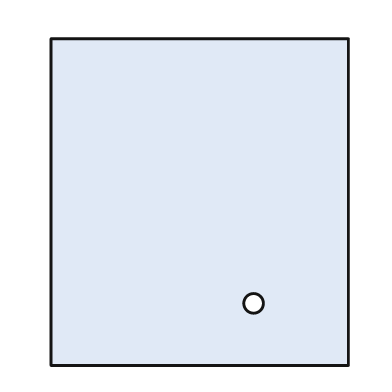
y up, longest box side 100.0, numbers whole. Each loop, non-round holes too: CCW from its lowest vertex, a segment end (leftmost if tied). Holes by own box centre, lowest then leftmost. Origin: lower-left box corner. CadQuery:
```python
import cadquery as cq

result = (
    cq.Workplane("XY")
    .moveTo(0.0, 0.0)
    .lineTo(91.0, 0.0)
    .lineTo(91.0, 100.0)
    .lineTo(0.0, 100.0)
    .close()
    .moveTo(62.0, 19.0)
    .circle(3.0)
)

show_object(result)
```